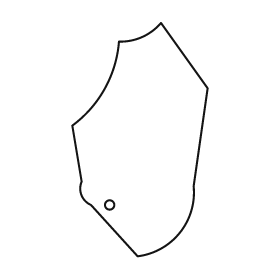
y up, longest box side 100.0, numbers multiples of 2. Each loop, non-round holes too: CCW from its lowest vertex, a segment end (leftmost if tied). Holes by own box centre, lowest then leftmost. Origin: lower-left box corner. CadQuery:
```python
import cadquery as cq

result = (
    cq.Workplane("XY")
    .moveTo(28.0, 0.0)
    .threePointArc((46.0, 10.0), (52.0, 30.0))
    .lineTo(58.0, 72.0)
    .lineTo(38.0, 100.0)
    .threePointArc((30.0, 94.0), (20.0, 92.0))
    .threePointArc((14.0, 72.0), (0.0, 56.0))
    .lineTo(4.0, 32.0)
    .threePointArc((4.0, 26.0), (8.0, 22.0))
    .close()
    .moveTo(16.0, 22.0)
    .circle(2.0)
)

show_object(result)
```